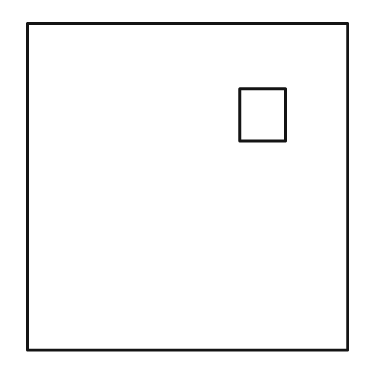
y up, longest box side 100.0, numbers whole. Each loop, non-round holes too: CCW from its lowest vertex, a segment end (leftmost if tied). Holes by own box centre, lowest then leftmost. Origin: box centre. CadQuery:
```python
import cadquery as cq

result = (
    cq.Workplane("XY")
    .moveTo(-49.0, -50.0)
    .lineTo(49.0, -50.0)
    .lineTo(49.0, 50.0)
    .lineTo(-49.0, 50.0)
    .close()
    .moveTo(16.0, 14.0)
    .lineTo(30.0, 14.0)
    .lineTo(30.0, 30.0)
    .lineTo(16.0, 30.0)
    .close()
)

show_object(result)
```